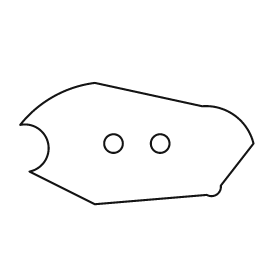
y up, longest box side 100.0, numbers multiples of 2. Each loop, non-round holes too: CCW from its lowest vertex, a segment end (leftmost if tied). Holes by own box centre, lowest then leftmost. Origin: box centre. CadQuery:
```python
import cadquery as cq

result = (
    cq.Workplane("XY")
    .moveTo(-18.0, -26.0)
    .lineTo(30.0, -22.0)
    .threePointArc((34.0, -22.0), (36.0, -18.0))
    .lineTo(50.0, 0.0)
    .threePointArc((42.0, 12.0), (28.0, 16.0))
    .lineTo(-18.0, 26.0)
    .threePointArc((-36.0, 20.0), (-50.0, 8.0))
    .threePointArc((-38.0, 0.0), (-46.0, -12.0))
    .close()
    .moveTo(-10.0, 0.0)
    .circle(4.0)
    .moveTo(10.0, 0.0)
    .circle(4.0)
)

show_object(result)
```